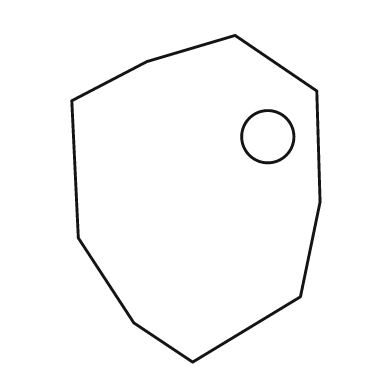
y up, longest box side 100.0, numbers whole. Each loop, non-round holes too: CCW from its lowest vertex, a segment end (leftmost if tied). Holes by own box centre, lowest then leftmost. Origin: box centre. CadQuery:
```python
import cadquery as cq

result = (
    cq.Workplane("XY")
    .moveTo(-1.0, -50.0)
    .lineTo(32.0, -30.0)
    .lineTo(38.0, -1.0)
    .lineTo(37.0, 33.0)
    .lineTo(12.0, 50.0)
    .lineTo(-15.0, 42.0)
    .lineTo(-38.0, 30.0)
    .lineTo(-36.0, -12.0)
    .lineTo(-19.0, -38.0)
    .close()
    .moveTo(22.0, 19.0)
    .circle(8.0)
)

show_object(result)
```